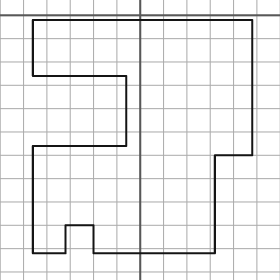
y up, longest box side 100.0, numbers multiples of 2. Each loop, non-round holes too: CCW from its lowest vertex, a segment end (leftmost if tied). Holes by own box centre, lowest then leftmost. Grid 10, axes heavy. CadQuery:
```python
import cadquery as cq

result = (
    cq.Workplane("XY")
    .moveTo(-46.0, -102.0)
    .lineTo(-32.0, -102.0)
    .lineTo(-32.0, -90.0)
    .lineTo(-20.0, -90.0)
    .lineTo(-20.0, -102.0)
    .lineTo(32.0, -102.0)
    .lineTo(32.0, -60.0)
    .lineTo(48.0, -60.0)
    .lineTo(48.0, -2.0)
    .lineTo(-46.0, -2.0)
    .lineTo(-46.0, -26.0)
    .lineTo(-6.0, -26.0)
    .lineTo(-6.0, -56.0)
    .lineTo(-46.0, -56.0)
    .close()
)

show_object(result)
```